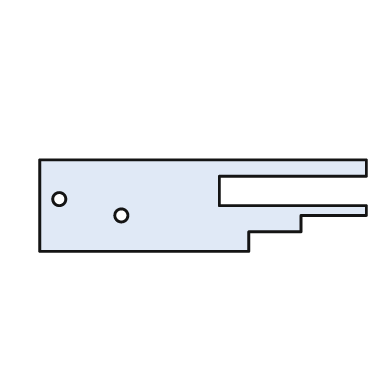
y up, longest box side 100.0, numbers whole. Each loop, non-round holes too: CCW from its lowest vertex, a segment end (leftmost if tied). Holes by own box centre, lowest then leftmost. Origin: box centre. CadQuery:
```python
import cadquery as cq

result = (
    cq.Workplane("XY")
    .moveTo(-50.0, -14.0)
    .lineTo(14.0, -14.0)
    .lineTo(14.0, -8.0)
    .lineTo(30.0, -8.0)
    .lineTo(30.0, -3.0)
    .lineTo(50.0, -3.0)
    .lineTo(50.0, 0.0)
    .lineTo(5.0, 0.0)
    .lineTo(5.0, 9.0)
    .lineTo(50.0, 9.0)
    .lineTo(50.0, 14.0)
    .lineTo(-50.0, 14.0)
    .close()
    .moveTo(-25.0, -3.0)
    .circle(2.0)
    .moveTo(-44.0, 2.0)
    .circle(2.0)
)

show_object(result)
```